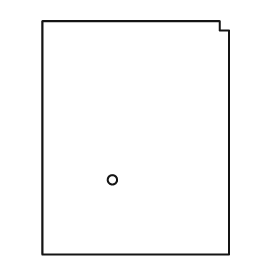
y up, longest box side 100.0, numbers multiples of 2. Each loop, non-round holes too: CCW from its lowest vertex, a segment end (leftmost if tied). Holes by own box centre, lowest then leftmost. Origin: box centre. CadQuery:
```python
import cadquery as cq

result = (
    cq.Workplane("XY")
    .moveTo(-40.0, -50.0)
    .lineTo(40.0, -50.0)
    .lineTo(40.0, 46.0)
    .lineTo(36.0, 46.0)
    .lineTo(36.0, 50.0)
    .lineTo(-40.0, 50.0)
    .close()
    .moveTo(-10.0, -18.0)
    .circle(2.0)
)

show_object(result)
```